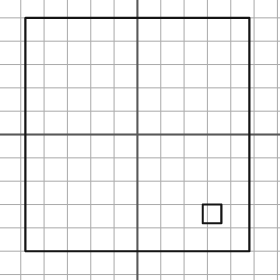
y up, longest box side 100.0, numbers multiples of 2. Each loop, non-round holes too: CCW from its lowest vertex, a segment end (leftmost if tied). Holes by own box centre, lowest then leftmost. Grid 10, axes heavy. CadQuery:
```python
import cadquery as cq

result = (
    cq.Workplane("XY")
    .moveTo(-48.0, -50.0)
    .lineTo(48.0, -50.0)
    .lineTo(48.0, 50.0)
    .lineTo(-48.0, 50.0)
    .close()
    .moveTo(28.0, -38.0)
    .lineTo(36.0, -38.0)
    .lineTo(36.0, -30.0)
    .lineTo(28.0, -30.0)
    .close()
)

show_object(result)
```